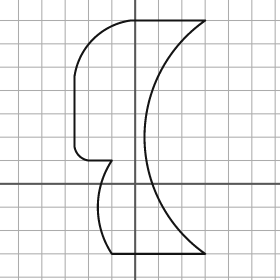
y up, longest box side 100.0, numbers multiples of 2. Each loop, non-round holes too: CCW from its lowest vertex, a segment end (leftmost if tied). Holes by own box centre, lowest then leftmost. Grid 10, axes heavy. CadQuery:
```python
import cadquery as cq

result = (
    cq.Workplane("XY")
    .moveTo(-10.0, -30.0)
    .lineTo(30.0, -30.0)
    .threePointArc((4.0, 20.0), (30.0, 70.0))
    .lineTo(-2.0, 70.0)
    .threePointArc((-18.0, 62.0), (-26.0, 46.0))
    .lineTo(-26.0, 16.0)
    .threePointArc((-24.0, 12.0), (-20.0, 10.0))
    .lineTo(-10.0, 10.0)
    .threePointArc((-16.0, -10.0), (-10.0, -30.0))
    .close()
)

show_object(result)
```